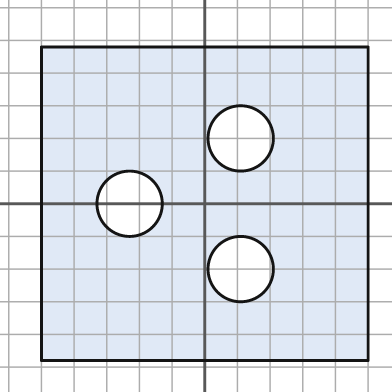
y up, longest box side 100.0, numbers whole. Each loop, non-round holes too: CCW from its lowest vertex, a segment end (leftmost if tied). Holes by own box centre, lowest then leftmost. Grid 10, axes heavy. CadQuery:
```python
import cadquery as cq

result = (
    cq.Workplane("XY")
    .moveTo(-50.0, -48.0)
    .lineTo(50.0, -48.0)
    .lineTo(50.0, 48.0)
    .lineTo(-50.0, 48.0)
    .close()
    .moveTo(11.0, -20.0)
    .circle(10.0)
    .moveTo(-23.0, 0.0)
    .circle(10.0)
    .moveTo(11.0, 20.0)
    .circle(10.0)
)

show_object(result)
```